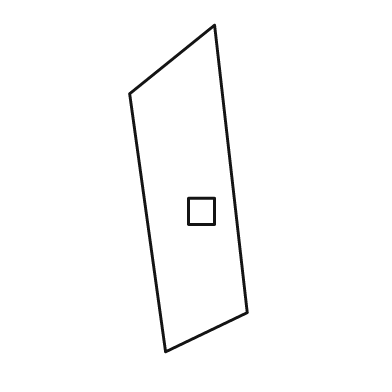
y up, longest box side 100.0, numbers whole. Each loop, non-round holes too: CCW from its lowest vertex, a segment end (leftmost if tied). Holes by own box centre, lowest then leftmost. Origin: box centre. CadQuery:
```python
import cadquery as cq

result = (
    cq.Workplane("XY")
    .moveTo(-7.0, -50.0)
    .lineTo(18.0, -38.0)
    .lineTo(8.0, 50.0)
    .lineTo(-18.0, 29.0)
    .close()
    .moveTo(0.0, -11.0)
    .lineTo(8.0, -11.0)
    .lineTo(8.0, -3.0)
    .lineTo(0.0, -3.0)
    .close()
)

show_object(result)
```